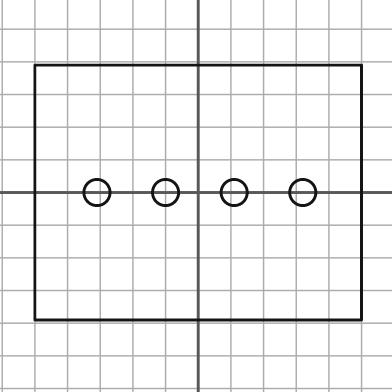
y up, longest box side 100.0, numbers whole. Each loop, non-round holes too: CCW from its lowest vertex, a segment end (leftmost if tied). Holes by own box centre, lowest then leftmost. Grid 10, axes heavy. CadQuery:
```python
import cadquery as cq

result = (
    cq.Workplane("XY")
    .moveTo(-50.0, -39.0)
    .lineTo(50.0, -39.0)
    .lineTo(50.0, 39.0)
    .lineTo(-50.0, 39.0)
    .close()
    .moveTo(-31.0, 0.0)
    .circle(4.0)
    .moveTo(-10.0, 0.0)
    .circle(4.0)
    .moveTo(11.0, 0.0)
    .circle(4.0)
    .moveTo(32.0, 0.0)
    .circle(4.0)
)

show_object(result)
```